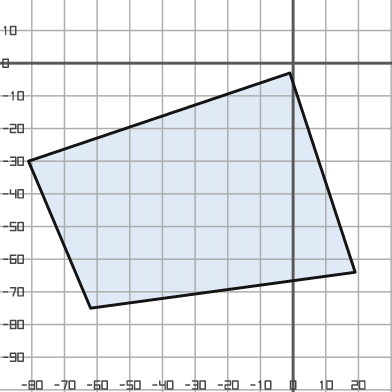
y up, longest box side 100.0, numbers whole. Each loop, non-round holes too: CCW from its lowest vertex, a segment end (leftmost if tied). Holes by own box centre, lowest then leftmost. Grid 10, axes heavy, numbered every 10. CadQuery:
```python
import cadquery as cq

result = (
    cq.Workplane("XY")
    .moveTo(-62.0, -75.0)
    .lineTo(19.0, -64.0)
    .lineTo(-1.0, -3.0)
    .lineTo(-81.0, -30.0)
    .close()
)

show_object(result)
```